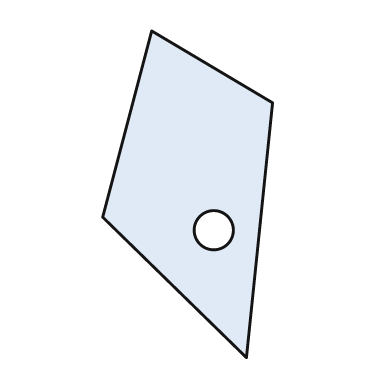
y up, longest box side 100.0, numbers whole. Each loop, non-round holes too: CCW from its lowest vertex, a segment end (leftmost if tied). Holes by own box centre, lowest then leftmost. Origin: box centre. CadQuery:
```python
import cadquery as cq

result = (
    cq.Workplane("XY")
    .moveTo(18.0, -50.0)
    .lineTo(26.0, 28.0)
    .lineTo(-11.0, 50.0)
    .lineTo(-26.0, -7.0)
    .close()
    .moveTo(8.0, -11.0)
    .circle(6.0)
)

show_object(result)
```